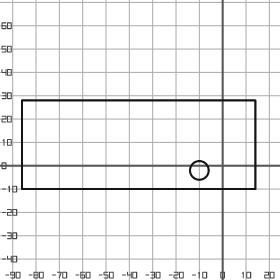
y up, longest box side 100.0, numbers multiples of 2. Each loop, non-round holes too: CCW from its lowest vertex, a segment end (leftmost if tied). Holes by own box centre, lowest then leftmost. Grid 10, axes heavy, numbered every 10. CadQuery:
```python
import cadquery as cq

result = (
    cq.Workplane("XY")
    .moveTo(-86.0, -10.0)
    .lineTo(14.0, -10.0)
    .lineTo(14.0, 28.0)
    .lineTo(-86.0, 28.0)
    .close()
    .moveTo(-10.0, -2.0)
    .circle(4.0)
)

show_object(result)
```